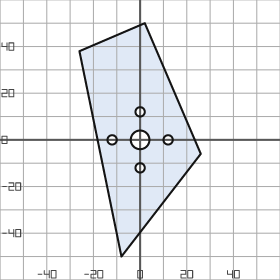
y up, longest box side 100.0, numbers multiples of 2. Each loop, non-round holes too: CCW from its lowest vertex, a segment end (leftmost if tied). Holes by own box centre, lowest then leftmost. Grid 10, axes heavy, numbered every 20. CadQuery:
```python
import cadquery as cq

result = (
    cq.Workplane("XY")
    .moveTo(-8.0, -50.0)
    .lineTo(26.0, -6.0)
    .lineTo(2.0, 50.0)
    .lineTo(-26.0, 38.0)
    .close()
    .moveTo(0.0, -12.0)
    .circle(2.0)
    .moveTo(-12.0, 0.0)
    .circle(2.0)
    .moveTo(0.0, 0.0)
    .circle(4.0)
    .moveTo(12.0, 0.0)
    .circle(2.0)
    .moveTo(0.0, 12.0)
    .circle(2.0)
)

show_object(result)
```